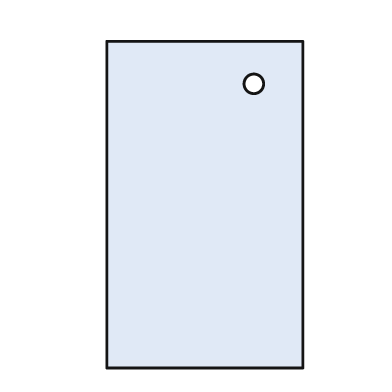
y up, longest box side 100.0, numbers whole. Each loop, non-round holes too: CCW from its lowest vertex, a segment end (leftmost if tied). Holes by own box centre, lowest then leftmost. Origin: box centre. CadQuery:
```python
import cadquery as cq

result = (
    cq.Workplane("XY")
    .moveTo(-30.0, -50.0)
    .lineTo(30.0, -50.0)
    .lineTo(30.0, 50.0)
    .lineTo(-30.0, 50.0)
    .close()
    .moveTo(15.0, 37.0)
    .circle(3.0)
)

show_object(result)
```